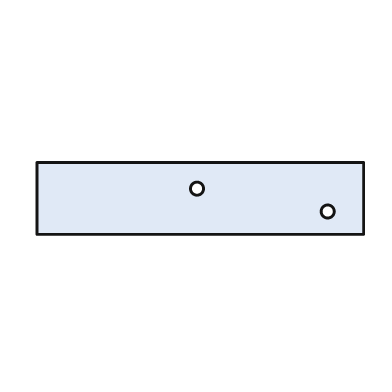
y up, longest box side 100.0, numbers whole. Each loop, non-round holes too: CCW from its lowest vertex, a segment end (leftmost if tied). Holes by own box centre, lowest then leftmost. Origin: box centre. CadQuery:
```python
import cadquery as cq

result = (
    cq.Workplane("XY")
    .moveTo(-50.0, -11.0)
    .lineTo(50.0, -11.0)
    .lineTo(50.0, 11.0)
    .lineTo(-50.0, 11.0)
    .close()
    .moveTo(39.0, -4.0)
    .circle(2.0)
    .moveTo(-1.0, 3.0)
    .circle(2.0)
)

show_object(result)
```